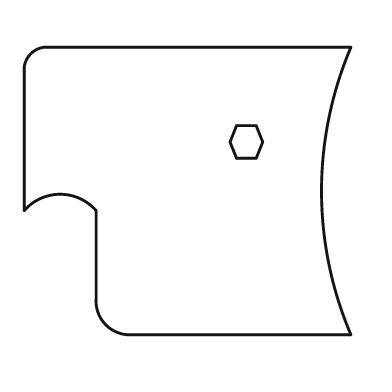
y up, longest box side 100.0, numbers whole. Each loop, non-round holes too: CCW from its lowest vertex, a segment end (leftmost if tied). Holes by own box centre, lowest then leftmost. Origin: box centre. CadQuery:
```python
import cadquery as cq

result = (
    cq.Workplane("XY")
    .moveTo(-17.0, -44.0)
    .lineTo(50.0, -44.0)
    .threePointArc((41.0, 0.0), (50.0, 44.0))
    .lineTo(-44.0, 44.0)
    .threePointArc((-48.0, 42.0), (-50.0, 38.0))
    .lineTo(-50.0, -6.0)
    .threePointArc((-39.0, -1.0), (-28.0, -6.0))
    .lineTo(-28.0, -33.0)
    .threePointArc((-25.0, -41.0), (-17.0, -44.0))
    .close()
    .moveTo(15.0, 10.0)
    .lineTo(21.0, 10.0)
    .lineTo(23.0, 15.0)
    .lineTo(21.0, 20.0)
    .lineTo(15.0, 20.0)
    .lineTo(13.0, 15.0)
    .close()
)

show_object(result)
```